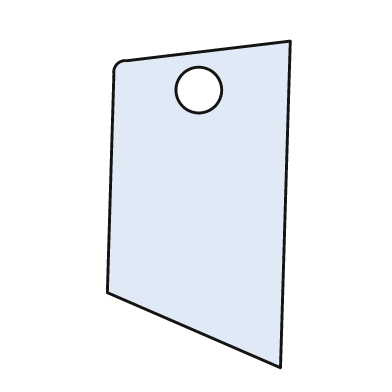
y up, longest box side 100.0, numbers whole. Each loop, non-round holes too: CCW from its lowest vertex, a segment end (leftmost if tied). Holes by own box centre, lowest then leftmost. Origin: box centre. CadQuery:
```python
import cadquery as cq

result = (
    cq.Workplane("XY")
    .moveTo(25.0, -50.0)
    .lineTo(28.0, 50.0)
    .lineTo(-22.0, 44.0)
    .threePointArc((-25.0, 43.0), (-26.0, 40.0))
    .lineTo(-28.0, -27.0)
    .close()
    .moveTo(0.0, 35.0)
    .circle(7.0)
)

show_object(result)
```